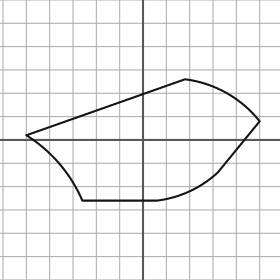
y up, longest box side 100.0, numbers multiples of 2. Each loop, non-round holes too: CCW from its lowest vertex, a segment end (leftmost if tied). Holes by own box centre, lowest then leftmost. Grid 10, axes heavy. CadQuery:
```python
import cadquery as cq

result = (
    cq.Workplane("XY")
    .moveTo(-26.0, -26.0)
    .lineTo(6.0, -26.0)
    .threePointArc((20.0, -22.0), (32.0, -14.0))
    .lineTo(50.0, 8.0)
    .threePointArc((36.0, 20.0), (18.0, 26.0))
    .lineTo(-50.0, 2.0)
    .threePointArc((-36.0, -10.0), (-26.0, -26.0))
    .close()
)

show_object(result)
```